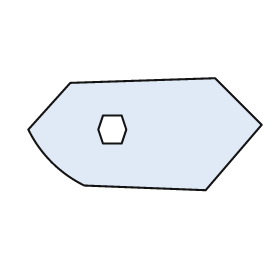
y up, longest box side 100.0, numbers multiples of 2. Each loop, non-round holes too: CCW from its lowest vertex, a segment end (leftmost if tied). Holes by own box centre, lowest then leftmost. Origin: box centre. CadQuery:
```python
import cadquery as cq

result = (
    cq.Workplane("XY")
    .moveTo(26.0, -24.0)
    .lineTo(50.0, 4.0)
    .lineTo(30.0, 24.0)
    .lineTo(-32.0, 22.0)
    .lineTo(-50.0, 2.0)
    .threePointArc((-40.0, -12.0), (-26.0, -22.0))
    .close()
    .moveTo(-18.0, -4.0)
    .lineTo(-10.0, -4.0)
    .lineTo(-8.0, 2.0)
    .lineTo(-10.0, 8.0)
    .lineTo(-18.0, 8.0)
    .lineTo(-20.0, 2.0)
    .close()
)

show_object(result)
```